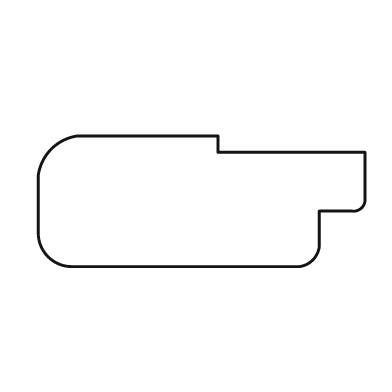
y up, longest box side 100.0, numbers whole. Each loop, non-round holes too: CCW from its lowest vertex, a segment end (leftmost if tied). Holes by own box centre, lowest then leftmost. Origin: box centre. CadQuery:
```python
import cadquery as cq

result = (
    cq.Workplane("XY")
    .moveTo(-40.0, -20.0)
    .lineTo(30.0, -20.0)
    .threePointArc((34.0, -18.0), (36.0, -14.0))
    .lineTo(36.0, -3.0)
    .lineTo(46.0, -3.0)
    .threePointArc((49.0, -2.0), (50.0, 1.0))
    .lineTo(50.0, 15.0)
    .lineTo(5.0, 15.0)
    .lineTo(5.0, 20.0)
    .lineTo(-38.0, 20.0)
    .threePointArc((-46.0, 16.0), (-50.0, 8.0))
    .lineTo(-50.0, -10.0)
    .threePointArc((-47.0, -17.0), (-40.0, -20.0))
    .close()
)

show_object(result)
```